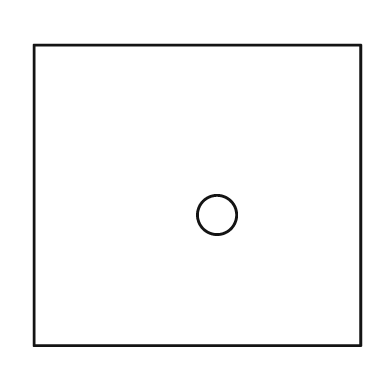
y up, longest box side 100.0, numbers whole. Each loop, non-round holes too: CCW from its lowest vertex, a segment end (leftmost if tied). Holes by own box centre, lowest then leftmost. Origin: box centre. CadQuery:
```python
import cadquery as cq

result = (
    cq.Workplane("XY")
    .moveTo(-50.0, -46.0)
    .lineTo(50.0, -46.0)
    .lineTo(50.0, 46.0)
    .lineTo(-50.0, 46.0)
    .close()
    .moveTo(6.0, -6.0)
    .circle(6.0)
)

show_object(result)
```